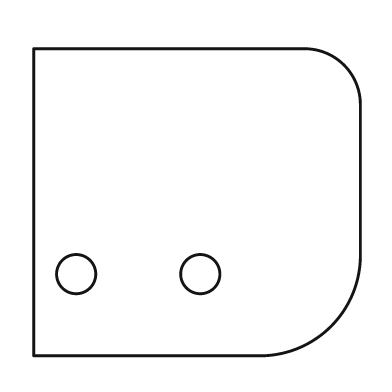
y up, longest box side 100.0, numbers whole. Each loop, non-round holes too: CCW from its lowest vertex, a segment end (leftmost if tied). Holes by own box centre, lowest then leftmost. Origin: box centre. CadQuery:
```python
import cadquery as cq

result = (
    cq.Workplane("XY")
    .moveTo(-50.0, -47.0)
    .lineTo(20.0, -47.0)
    .threePointArc((41.0, -38.0), (50.0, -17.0))
    .lineTo(50.0, 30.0)
    .threePointArc((45.0, 42.0), (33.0, 47.0))
    .lineTo(-50.0, 47.0)
    .close()
    .moveTo(-37.0, -22.0)
    .circle(6.0)
    .moveTo(1.0, -22.0)
    .circle(6.0)
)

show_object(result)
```